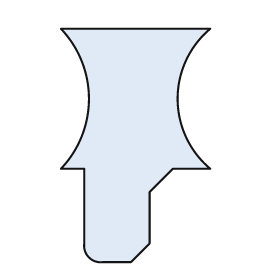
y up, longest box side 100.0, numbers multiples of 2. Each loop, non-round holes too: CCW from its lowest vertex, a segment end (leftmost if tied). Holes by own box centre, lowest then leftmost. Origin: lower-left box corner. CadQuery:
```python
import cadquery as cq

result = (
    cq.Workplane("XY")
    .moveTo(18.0, 0.0)
    .lineTo(30.0, 0.0)
    .lineTo(38.0, 8.0)
    .lineTo(38.0, 30.0)
    .lineTo(48.0, 40.0)
    .lineTo(64.0, 40.0)
    .threePointArc((50.0, 70.0), (64.0, 100.0))
    .lineTo(0.0, 100.0)
    .threePointArc((12.0, 70.0), (0.0, 40.0))
    .lineTo(10.0, 40.0)
    .lineTo(10.0, 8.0)
    .threePointArc((12.0, 2.0), (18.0, 0.0))
    .close()
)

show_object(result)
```